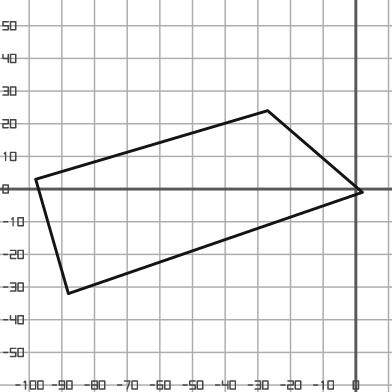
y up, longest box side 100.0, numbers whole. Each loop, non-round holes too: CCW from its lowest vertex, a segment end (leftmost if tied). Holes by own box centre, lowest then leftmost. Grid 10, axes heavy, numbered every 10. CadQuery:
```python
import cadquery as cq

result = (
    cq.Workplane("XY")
    .moveTo(-88.0, -32.0)
    .lineTo(2.0, -1.0)
    .lineTo(-27.0, 24.0)
    .lineTo(-98.0, 3.0)
    .close()
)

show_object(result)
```